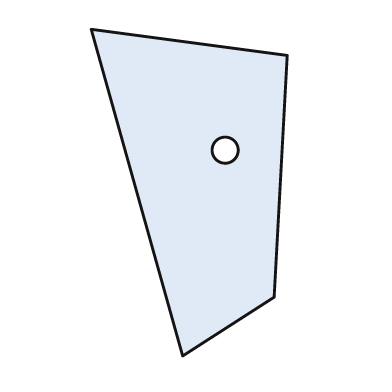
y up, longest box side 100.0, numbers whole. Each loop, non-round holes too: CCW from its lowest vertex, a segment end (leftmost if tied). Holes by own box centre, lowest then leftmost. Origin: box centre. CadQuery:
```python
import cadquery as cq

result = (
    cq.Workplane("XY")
    .moveTo(-2.0, -50.0)
    .lineTo(26.0, -32.0)
    .lineTo(30.0, 42.0)
    .lineTo(-30.0, 50.0)
    .close()
    .moveTo(11.0, 13.0)
    .circle(4.0)
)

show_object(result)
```